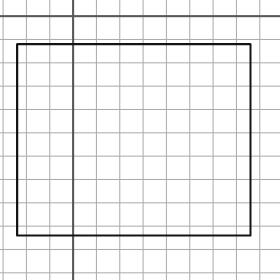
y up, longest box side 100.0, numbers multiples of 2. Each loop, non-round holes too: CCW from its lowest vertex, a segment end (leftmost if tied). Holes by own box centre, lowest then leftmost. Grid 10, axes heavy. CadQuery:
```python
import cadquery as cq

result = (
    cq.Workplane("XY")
    .moveTo(-24.0, -94.0)
    .lineTo(76.0, -94.0)
    .lineTo(76.0, -12.0)
    .lineTo(-24.0, -12.0)
    .close()
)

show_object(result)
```